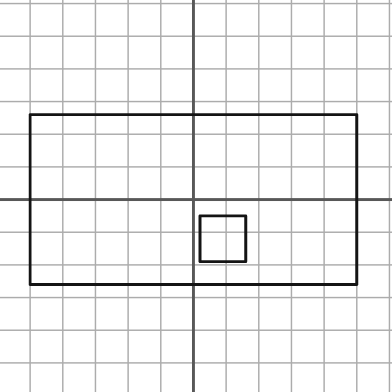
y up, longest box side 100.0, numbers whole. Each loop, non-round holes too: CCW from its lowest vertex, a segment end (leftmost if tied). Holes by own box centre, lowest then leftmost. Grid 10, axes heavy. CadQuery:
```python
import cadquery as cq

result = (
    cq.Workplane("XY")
    .moveTo(-50.0, -26.0)
    .lineTo(50.0, -26.0)
    .lineTo(50.0, 26.0)
    .lineTo(-50.0, 26.0)
    .close()
    .moveTo(2.0, -19.0)
    .lineTo(16.0, -19.0)
    .lineTo(16.0, -5.0)
    .lineTo(2.0, -5.0)
    .close()
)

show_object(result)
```